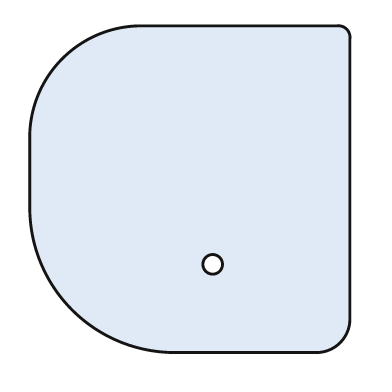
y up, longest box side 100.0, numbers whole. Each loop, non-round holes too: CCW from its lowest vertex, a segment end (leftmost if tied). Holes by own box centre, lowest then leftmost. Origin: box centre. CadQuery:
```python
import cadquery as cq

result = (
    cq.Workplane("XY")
    .moveTo(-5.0, -50.0)
    .lineTo(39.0, -50.0)
    .threePointArc((46.0, -47.0), (49.0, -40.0))
    .lineTo(49.0, 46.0)
    .threePointArc((48.0, 49.0), (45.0, 50.0))
    .lineTo(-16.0, 50.0)
    .threePointArc((-39.0, 40.0), (-49.0, 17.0))
    .lineTo(-49.0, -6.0)
    .threePointArc((-36.0, -37.0), (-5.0, -50.0))
    .close()
    .moveTo(7.0, -23.0)
    .circle(3.0)
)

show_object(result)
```